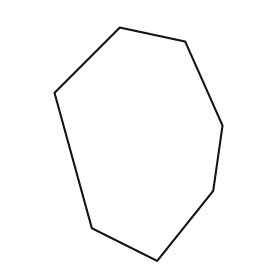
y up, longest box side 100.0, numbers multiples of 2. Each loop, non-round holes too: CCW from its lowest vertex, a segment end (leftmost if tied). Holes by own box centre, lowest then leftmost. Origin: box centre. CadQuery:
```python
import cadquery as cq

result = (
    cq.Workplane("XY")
    .moveTo(8.0, -50.0)
    .lineTo(32.0, -20.0)
    .lineTo(36.0, 8.0)
    .lineTo(20.0, 44.0)
    .lineTo(-8.0, 50.0)
    .lineTo(-36.0, 22.0)
    .lineTo(-20.0, -36.0)
    .close()
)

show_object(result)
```